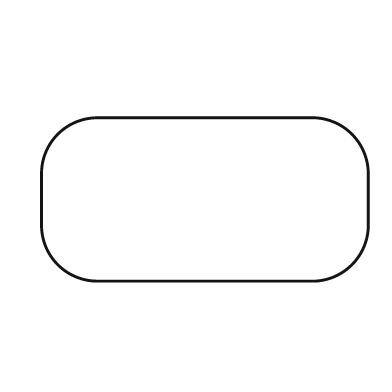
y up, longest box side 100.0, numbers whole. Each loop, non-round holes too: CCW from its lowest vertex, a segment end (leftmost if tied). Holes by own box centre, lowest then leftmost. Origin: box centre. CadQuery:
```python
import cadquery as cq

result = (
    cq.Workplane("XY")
    .moveTo(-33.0, -25.0)
    .lineTo(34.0, -25.0)
    .threePointArc((45.0, -20.0), (50.0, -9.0))
    .lineTo(50.0, 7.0)
    .threePointArc((45.0, 20.0), (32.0, 25.0))
    .lineTo(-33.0, 25.0)
    .threePointArc((-45.0, 20.0), (-50.0, 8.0))
    .lineTo(-50.0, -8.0)
    .threePointArc((-45.0, -20.0), (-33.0, -25.0))
    .close()
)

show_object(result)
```